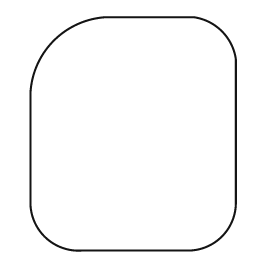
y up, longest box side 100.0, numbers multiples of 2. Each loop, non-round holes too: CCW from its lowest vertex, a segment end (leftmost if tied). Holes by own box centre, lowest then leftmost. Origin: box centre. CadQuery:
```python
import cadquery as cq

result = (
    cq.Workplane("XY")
    .moveTo(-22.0, -50.0)
    .lineTo(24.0, -50.0)
    .threePointArc((38.0, -44.0), (44.0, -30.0))
    .lineTo(44.0, 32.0)
    .threePointArc((38.0, 44.0), (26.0, 50.0))
    .lineTo(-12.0, 50.0)
    .threePointArc((-34.0, 40.0), (-44.0, 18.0))
    .lineTo(-44.0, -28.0)
    .threePointArc((-38.0, -44.0), (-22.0, -50.0))
    .close()
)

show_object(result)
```